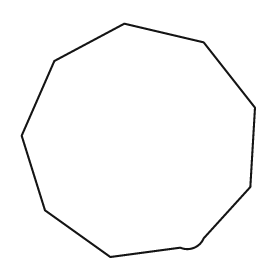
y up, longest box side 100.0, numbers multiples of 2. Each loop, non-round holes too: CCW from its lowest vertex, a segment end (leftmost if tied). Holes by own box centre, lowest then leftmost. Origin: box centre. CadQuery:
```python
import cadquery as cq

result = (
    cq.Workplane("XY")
    .moveTo(-12.0, -50.0)
    .lineTo(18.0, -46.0)
    .threePointArc((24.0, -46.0), (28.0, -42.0))
    .lineTo(48.0, -20.0)
    .lineTo(50.0, 14.0)
    .lineTo(28.0, 42.0)
    .lineTo(-6.0, 50.0)
    .lineTo(-36.0, 34.0)
    .lineTo(-50.0, 2.0)
    .lineTo(-40.0, -30.0)
    .close()
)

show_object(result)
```